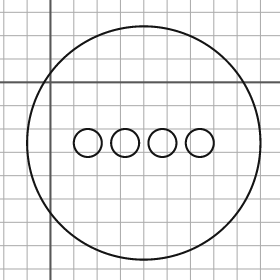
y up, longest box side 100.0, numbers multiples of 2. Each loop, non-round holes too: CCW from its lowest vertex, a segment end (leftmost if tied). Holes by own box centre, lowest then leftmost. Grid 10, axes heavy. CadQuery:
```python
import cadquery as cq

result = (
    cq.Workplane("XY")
    .moveTo(40.0, -26.0)
    .circle(50.0)
    .moveTo(16.0, -26.0)
    .circle(6.0)
    .moveTo(32.0, -26.0)
    .circle(6.0)
    .moveTo(48.0, -26.0)
    .circle(6.0)
    .moveTo(64.0, -26.0)
    .circle(6.0)
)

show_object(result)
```